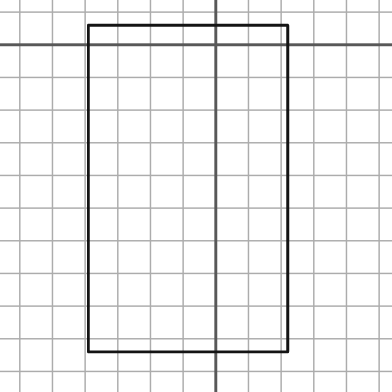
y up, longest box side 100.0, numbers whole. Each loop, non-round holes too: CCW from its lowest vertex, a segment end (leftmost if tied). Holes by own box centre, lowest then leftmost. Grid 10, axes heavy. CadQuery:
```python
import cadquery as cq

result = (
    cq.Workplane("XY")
    .moveTo(-39.0, -94.0)
    .lineTo(22.0, -94.0)
    .lineTo(22.0, 6.0)
    .lineTo(-39.0, 6.0)
    .close()
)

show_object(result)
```